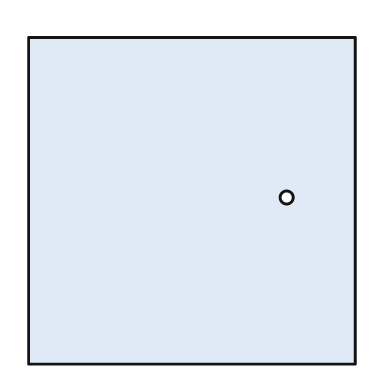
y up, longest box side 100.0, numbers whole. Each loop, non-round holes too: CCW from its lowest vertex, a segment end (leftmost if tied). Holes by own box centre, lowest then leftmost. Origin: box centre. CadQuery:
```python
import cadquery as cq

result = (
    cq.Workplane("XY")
    .moveTo(-50.0, -50.0)
    .lineTo(50.0, -50.0)
    .lineTo(50.0, 50.0)
    .lineTo(-50.0, 50.0)
    .close()
    .moveTo(29.0, 1.0)
    .circle(2.0)
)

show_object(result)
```